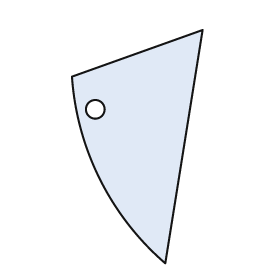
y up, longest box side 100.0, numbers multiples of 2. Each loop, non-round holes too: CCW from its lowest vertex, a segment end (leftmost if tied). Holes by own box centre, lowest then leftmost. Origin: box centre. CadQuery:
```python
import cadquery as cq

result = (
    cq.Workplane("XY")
    .moveTo(12.0, -50.0)
    .lineTo(28.0, 50.0)
    .lineTo(-28.0, 30.0)
    .threePointArc((-16.0, -14.0), (12.0, -50.0))
    .close()
    .moveTo(-18.0, 16.0)
    .circle(4.0)
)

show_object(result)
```